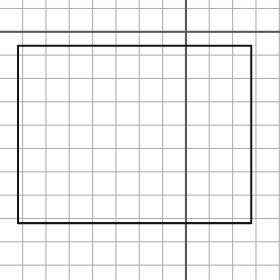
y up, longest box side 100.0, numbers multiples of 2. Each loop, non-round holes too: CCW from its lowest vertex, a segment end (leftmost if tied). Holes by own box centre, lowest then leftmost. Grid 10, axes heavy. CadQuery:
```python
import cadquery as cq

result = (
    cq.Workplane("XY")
    .moveTo(-72.0, -82.0)
    .lineTo(28.0, -82.0)
    .lineTo(28.0, -6.0)
    .lineTo(-72.0, -6.0)
    .close()
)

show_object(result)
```